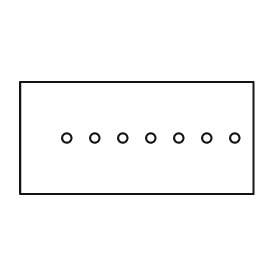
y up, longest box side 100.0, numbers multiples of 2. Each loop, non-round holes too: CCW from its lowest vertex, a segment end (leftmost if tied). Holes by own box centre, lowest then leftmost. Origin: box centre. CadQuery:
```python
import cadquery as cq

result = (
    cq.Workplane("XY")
    .moveTo(-50.0, -24.0)
    .lineTo(50.0, -24.0)
    .lineTo(50.0, 24.0)
    .lineTo(-50.0, 24.0)
    .close()
    .moveTo(-30.0, 0.0)
    .circle(2.0)
    .moveTo(-18.0, 0.0)
    .circle(2.0)
    .moveTo(-6.0, 0.0)
    .circle(2.0)
    .moveTo(6.0, 0.0)
    .circle(2.0)
    .moveTo(18.0, 0.0)
    .circle(2.0)
    .moveTo(30.0, 0.0)
    .circle(2.0)
    .moveTo(42.0, 0.0)
    .circle(2.0)
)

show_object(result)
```